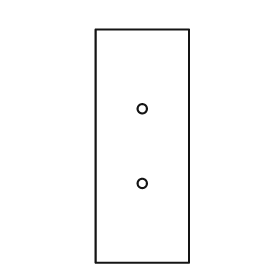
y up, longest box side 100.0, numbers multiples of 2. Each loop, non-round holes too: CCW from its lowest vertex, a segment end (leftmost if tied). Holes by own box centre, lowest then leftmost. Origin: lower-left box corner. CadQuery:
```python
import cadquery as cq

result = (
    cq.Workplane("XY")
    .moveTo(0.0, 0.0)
    .lineTo(40.0, 0.0)
    .lineTo(40.0, 100.0)
    .lineTo(0.0, 100.0)
    .close()
    .moveTo(20.0, 34.0)
    .circle(2.0)
    .moveTo(20.0, 66.0)
    .circle(2.0)
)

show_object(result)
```